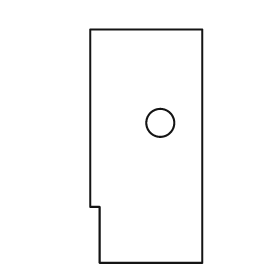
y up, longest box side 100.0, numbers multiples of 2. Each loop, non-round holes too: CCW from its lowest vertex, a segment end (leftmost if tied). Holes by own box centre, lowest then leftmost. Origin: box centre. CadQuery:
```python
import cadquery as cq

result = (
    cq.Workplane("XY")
    .moveTo(-20.0, -50.0)
    .lineTo(24.0, -50.0)
    .lineTo(24.0, 50.0)
    .lineTo(-24.0, 50.0)
    .lineTo(-24.0, -26.0)
    .lineTo(-20.0, -26.0)
    .close()
    .moveTo(6.0, 10.0)
    .circle(6.0)
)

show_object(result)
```